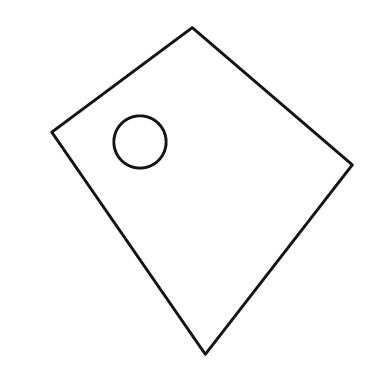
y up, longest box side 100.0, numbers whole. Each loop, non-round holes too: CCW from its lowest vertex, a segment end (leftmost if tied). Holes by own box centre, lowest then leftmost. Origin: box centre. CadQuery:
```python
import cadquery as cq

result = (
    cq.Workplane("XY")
    .moveTo(1.0, -50.0)
    .lineTo(46.0, 8.0)
    .lineTo(-3.0, 50.0)
    .lineTo(-46.0, 18.0)
    .close()
    .moveTo(-19.0, 15.0)
    .circle(8.0)
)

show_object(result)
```